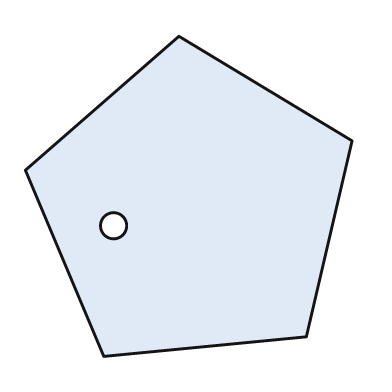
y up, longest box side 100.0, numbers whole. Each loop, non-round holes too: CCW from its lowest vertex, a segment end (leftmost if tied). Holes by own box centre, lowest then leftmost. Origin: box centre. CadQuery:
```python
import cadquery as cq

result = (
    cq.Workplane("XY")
    .moveTo(-26.0, -49.0)
    .lineTo(36.0, -43.0)
    .lineTo(50.0, 17.0)
    .lineTo(-3.0, 49.0)
    .lineTo(-50.0, 8.0)
    .close()
    .moveTo(-23.0, -9.0)
    .circle(4.0)
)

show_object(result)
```